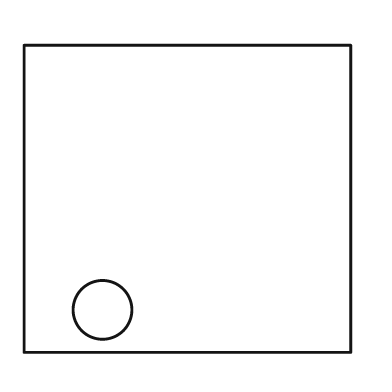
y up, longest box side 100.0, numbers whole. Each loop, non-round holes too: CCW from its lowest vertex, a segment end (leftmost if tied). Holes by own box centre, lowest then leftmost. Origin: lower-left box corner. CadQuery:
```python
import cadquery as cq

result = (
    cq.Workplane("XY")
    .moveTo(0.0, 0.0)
    .lineTo(100.0, 0.0)
    .lineTo(100.0, 94.0)
    .lineTo(0.0, 94.0)
    .close()
    .moveTo(24.0, 13.0)
    .circle(9.0)
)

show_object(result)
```